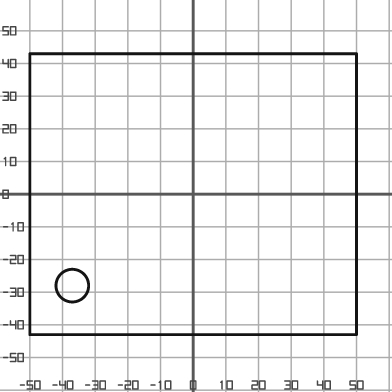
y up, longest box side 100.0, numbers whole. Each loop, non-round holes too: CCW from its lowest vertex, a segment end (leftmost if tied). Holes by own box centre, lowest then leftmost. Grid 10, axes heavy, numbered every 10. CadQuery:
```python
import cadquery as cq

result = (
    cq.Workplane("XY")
    .moveTo(-50.0, -43.0)
    .lineTo(50.0, -43.0)
    .lineTo(50.0, 43.0)
    .lineTo(-50.0, 43.0)
    .close()
    .moveTo(-37.0, -28.0)
    .circle(5.0)
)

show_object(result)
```